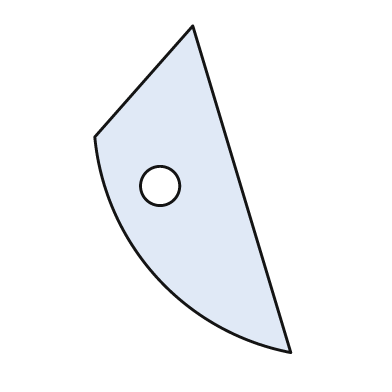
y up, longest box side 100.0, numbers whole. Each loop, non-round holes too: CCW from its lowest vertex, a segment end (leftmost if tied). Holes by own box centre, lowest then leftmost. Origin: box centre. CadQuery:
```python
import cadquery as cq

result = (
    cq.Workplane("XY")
    .moveTo(30.0, -50.0)
    .lineTo(0.0, 50.0)
    .lineTo(-30.0, 16.0)
    .threePointArc((-11.0, -27.0), (30.0, -50.0))
    .close()
    .moveTo(-10.0, 1.0)
    .circle(6.0)
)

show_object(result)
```